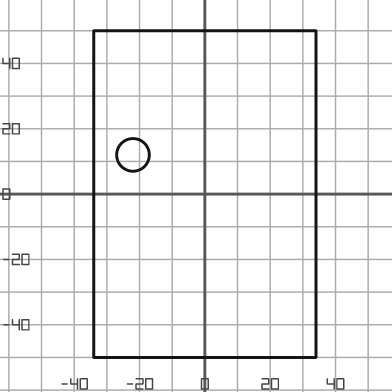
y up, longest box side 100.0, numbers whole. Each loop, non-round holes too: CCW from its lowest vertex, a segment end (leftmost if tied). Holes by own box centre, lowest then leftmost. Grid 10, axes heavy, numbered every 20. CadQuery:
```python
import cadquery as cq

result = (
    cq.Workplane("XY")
    .moveTo(-34.0, -50.0)
    .lineTo(34.0, -50.0)
    .lineTo(34.0, 50.0)
    .lineTo(-34.0, 50.0)
    .close()
    .moveTo(-22.0, 12.0)
    .circle(5.0)
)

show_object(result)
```